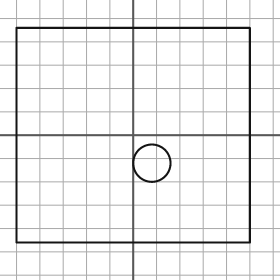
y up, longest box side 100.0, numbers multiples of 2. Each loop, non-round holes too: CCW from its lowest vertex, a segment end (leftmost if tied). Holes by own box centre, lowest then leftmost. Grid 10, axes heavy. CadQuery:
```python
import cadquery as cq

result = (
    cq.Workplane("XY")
    .moveTo(-50.0, -46.0)
    .lineTo(50.0, -46.0)
    .lineTo(50.0, 46.0)
    .lineTo(-50.0, 46.0)
    .close()
    .moveTo(8.0, -12.0)
    .circle(8.0)
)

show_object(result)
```